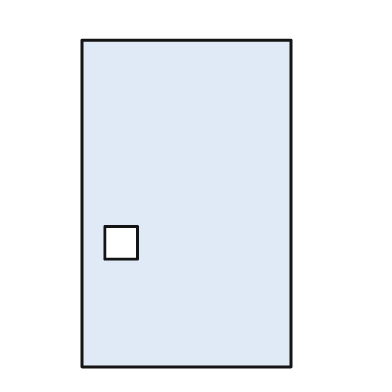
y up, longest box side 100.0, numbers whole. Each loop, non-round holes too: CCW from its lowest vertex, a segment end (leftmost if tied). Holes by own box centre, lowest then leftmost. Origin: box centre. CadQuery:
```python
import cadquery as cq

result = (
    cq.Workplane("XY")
    .moveTo(-32.0, -50.0)
    .lineTo(32.0, -50.0)
    .lineTo(32.0, 50.0)
    .lineTo(-32.0, 50.0)
    .close()
    .moveTo(-25.0, -17.0)
    .lineTo(-15.0, -17.0)
    .lineTo(-15.0, -7.0)
    .lineTo(-25.0, -7.0)
    .close()
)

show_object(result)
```